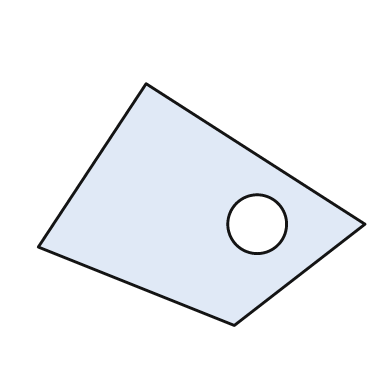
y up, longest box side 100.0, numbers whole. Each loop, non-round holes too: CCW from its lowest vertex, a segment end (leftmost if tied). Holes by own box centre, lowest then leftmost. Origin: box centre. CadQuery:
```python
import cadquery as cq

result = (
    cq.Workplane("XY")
    .moveTo(10.0, -37.0)
    .lineTo(50.0, -6.0)
    .lineTo(-17.0, 37.0)
    .lineTo(-50.0, -13.0)
    .close()
    .moveTo(17.0, -6.0)
    .circle(9.0)
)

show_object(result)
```